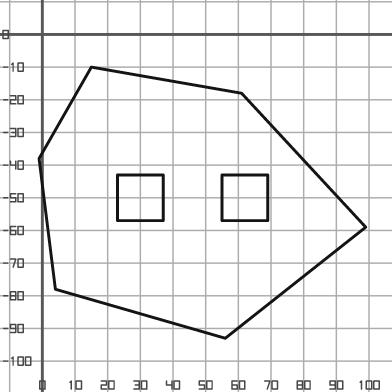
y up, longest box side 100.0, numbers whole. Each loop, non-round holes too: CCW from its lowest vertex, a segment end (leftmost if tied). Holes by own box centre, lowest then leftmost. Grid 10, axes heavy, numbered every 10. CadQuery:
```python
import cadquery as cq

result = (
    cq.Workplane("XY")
    .moveTo(56.0, -93.0)
    .lineTo(99.0, -59.0)
    .lineTo(61.0, -18.0)
    .lineTo(15.0, -10.0)
    .lineTo(-1.0, -38.0)
    .lineTo(4.0, -78.0)
    .close()
    .moveTo(23.0, -57.0)
    .lineTo(37.0, -57.0)
    .lineTo(37.0, -43.0)
    .lineTo(23.0, -43.0)
    .close()
    .moveTo(55.0, -57.0)
    .lineTo(69.0, -57.0)
    .lineTo(69.0, -43.0)
    .lineTo(55.0, -43.0)
    .close()
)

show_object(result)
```